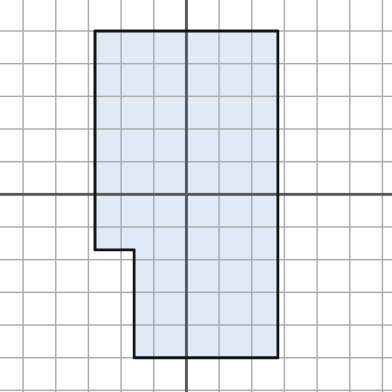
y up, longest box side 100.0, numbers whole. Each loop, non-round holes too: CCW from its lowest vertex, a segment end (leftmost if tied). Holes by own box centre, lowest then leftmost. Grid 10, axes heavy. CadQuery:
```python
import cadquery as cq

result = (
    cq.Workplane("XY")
    .moveTo(-16.0, -50.0)
    .lineTo(28.0, -50.0)
    .lineTo(28.0, 50.0)
    .lineTo(-28.0, 50.0)
    .lineTo(-28.0, -17.0)
    .lineTo(-16.0, -17.0)
    .close()
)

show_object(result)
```